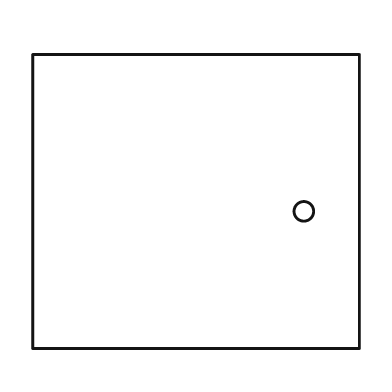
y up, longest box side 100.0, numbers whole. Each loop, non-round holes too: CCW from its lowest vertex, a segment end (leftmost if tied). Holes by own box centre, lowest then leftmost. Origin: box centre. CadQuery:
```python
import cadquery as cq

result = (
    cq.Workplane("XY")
    .moveTo(-50.0, -45.0)
    .lineTo(50.0, -45.0)
    .lineTo(50.0, 45.0)
    .lineTo(-50.0, 45.0)
    .close()
    .moveTo(33.0, -3.0)
    .circle(3.0)
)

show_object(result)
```